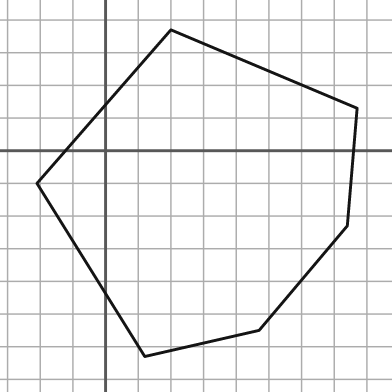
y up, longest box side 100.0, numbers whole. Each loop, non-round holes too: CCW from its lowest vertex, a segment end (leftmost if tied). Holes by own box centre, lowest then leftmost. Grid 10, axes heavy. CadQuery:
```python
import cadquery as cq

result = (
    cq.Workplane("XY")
    .moveTo(12.0, -63.0)
    .lineTo(47.0, -55.0)
    .lineTo(74.0, -23.0)
    .lineTo(77.0, 13.0)
    .lineTo(20.0, 37.0)
    .lineTo(-21.0, -10.0)
    .close()
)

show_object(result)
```